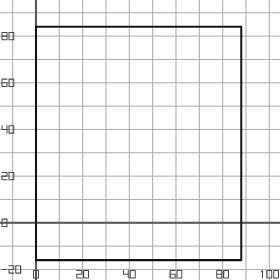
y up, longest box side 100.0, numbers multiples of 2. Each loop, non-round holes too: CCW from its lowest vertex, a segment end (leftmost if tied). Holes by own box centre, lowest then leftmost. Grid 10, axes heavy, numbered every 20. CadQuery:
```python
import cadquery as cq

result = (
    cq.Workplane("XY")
    .moveTo(0.0, -16.0)
    .lineTo(88.0, -16.0)
    .lineTo(88.0, 84.0)
    .lineTo(0.0, 84.0)
    .close()
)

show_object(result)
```